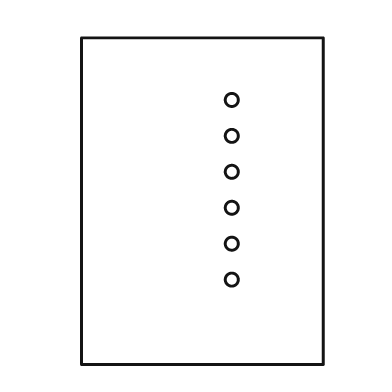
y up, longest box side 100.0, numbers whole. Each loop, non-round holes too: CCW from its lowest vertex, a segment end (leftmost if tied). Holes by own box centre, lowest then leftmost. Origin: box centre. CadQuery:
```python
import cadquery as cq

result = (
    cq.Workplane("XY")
    .moveTo(-37.0, -50.0)
    .lineTo(37.0, -50.0)
    .lineTo(37.0, 50.0)
    .lineTo(-37.0, 50.0)
    .close()
    .moveTo(9.0, -24.0)
    .circle(2.0)
    .moveTo(9.0, -13.0)
    .circle(2.0)
    .moveTo(9.0, -2.0)
    .circle(2.0)
    .moveTo(9.0, 9.0)
    .circle(2.0)
    .moveTo(9.0, 20.0)
    .circle(2.0)
    .moveTo(9.0, 31.0)
    .circle(2.0)
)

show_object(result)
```